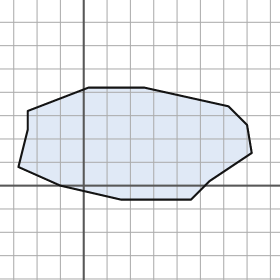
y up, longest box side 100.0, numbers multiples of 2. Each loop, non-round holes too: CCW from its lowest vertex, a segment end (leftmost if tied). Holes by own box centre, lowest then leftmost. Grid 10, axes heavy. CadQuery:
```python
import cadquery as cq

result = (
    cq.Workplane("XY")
    .moveTo(16.0, -6.0)
    .lineTo(46.0, -6.0)
    .lineTo(54.0, 2.0)
    .lineTo(72.0, 14.0)
    .lineTo(70.0, 26.0)
    .lineTo(62.0, 34.0)
    .lineTo(26.0, 42.0)
    .lineTo(2.0, 42.0)
    .lineTo(-24.0, 32.0)
    .lineTo(-24.0, 24.0)
    .lineTo(-28.0, 8.0)
    .lineTo(-10.0, 0.0)
    .close()
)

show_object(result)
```